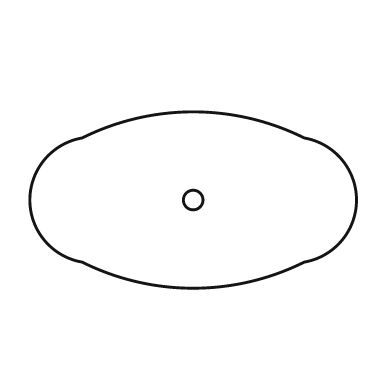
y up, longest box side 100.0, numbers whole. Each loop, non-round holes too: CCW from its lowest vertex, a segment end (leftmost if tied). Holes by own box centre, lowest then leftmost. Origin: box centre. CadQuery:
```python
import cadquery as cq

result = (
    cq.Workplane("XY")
    .moveTo(-34.0, -19.0)
    .threePointArc((0.0, -27.0), (34.0, -19.0))
    .threePointArc((50.0, 0.0), (34.0, 19.0))
    .threePointArc((0.0, 27.0), (-34.0, 19.0))
    .threePointArc((-50.0, 0.0), (-34.0, -19.0))
    .close()
    .moveTo(0.0, 0.0)
    .circle(3.0)
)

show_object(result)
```